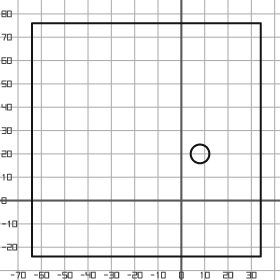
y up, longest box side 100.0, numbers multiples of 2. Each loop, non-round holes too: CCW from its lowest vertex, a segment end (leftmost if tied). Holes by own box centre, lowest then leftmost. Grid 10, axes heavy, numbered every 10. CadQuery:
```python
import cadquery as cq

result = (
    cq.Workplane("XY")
    .moveTo(-64.0, -24.0)
    .lineTo(34.0, -24.0)
    .lineTo(34.0, 76.0)
    .lineTo(-64.0, 76.0)
    .close()
    .moveTo(8.0, 20.0)
    .circle(4.0)
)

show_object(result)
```